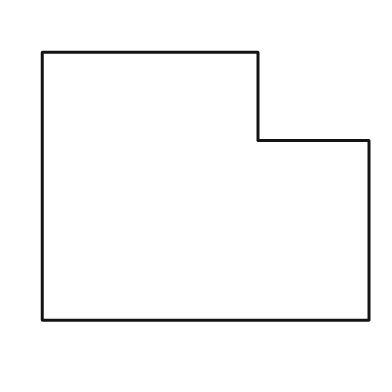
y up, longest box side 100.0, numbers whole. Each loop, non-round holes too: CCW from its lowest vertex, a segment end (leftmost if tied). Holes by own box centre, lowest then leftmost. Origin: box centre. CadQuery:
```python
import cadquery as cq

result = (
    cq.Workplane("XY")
    .moveTo(-50.0, -41.0)
    .lineTo(50.0, -41.0)
    .lineTo(50.0, 14.0)
    .lineTo(16.0, 14.0)
    .lineTo(16.0, 41.0)
    .lineTo(-50.0, 41.0)
    .close()
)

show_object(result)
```